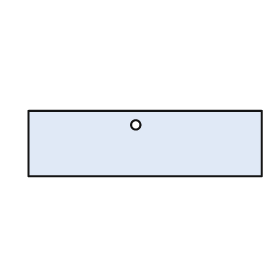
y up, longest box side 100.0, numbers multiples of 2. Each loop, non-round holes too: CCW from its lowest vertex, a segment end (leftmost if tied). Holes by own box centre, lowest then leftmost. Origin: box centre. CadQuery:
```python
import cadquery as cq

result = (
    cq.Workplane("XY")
    .moveTo(-50.0, -14.0)
    .lineTo(50.0, -14.0)
    .lineTo(50.0, 14.0)
    .lineTo(-50.0, 14.0)
    .close()
    .moveTo(-4.0, 8.0)
    .circle(2.0)
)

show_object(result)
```